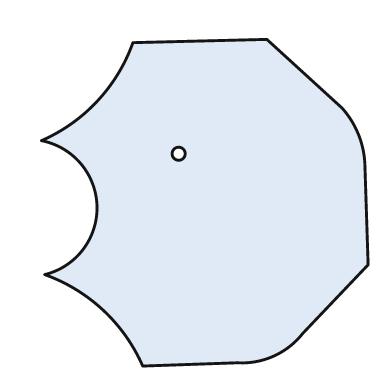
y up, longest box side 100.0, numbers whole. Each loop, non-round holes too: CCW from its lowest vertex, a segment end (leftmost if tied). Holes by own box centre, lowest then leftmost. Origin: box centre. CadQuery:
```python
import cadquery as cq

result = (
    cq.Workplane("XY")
    .moveTo(-19.0, -50.0)
    .lineTo(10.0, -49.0)
    .threePointArc((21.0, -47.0), (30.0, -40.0))
    .lineTo(50.0, -19.0)
    .lineTo(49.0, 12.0)
    .threePointArc((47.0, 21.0), (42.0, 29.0))
    .lineTo(19.0, 50.0)
    .lineTo(-22.0, 49.0)
    .threePointArc((-33.0, 31.0), (-50.0, 19.0))
    .threePointArc((-33.0, -1.0), (-49.0, -22.0))
    .threePointArc((-31.0, -33.0), (-19.0, -50.0))
    .close()
    .moveTo(-8.0, 15.0)
    .circle(2.0)
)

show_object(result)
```